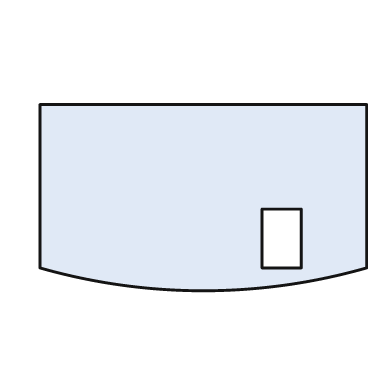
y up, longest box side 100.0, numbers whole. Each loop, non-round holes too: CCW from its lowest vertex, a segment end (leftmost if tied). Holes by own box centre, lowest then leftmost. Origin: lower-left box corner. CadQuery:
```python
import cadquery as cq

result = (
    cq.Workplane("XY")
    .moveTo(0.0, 7.0)
    .threePointArc((50.0, 0.0), (100.0, 7.0))
    .lineTo(100.0, 57.0)
    .lineTo(0.0, 57.0)
    .close()
    .moveTo(68.0, 7.0)
    .lineTo(80.0, 7.0)
    .lineTo(80.0, 25.0)
    .lineTo(68.0, 25.0)
    .close()
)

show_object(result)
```